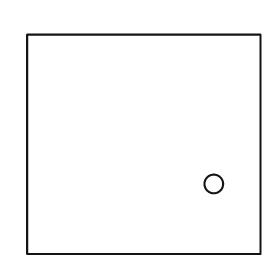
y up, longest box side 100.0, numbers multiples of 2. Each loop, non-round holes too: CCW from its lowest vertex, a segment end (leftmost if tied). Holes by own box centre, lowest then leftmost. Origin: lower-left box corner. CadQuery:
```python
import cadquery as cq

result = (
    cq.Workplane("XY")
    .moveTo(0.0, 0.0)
    .lineTo(100.0, 0.0)
    .lineTo(100.0, 94.0)
    .lineTo(0.0, 94.0)
    .close()
    .moveTo(80.0, 30.0)
    .circle(4.0)
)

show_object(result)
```